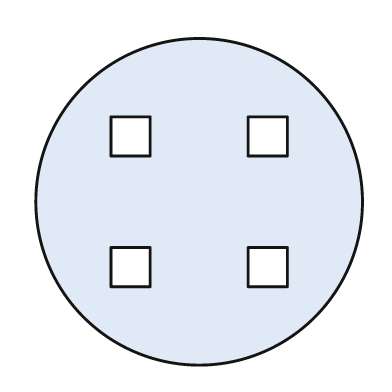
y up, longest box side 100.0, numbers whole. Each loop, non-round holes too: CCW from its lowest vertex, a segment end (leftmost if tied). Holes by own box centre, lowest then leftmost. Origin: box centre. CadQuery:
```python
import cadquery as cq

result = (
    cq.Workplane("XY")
    .moveTo(0.0, 0.0)
    .circle(50.0)
    .moveTo(-27.0, -26.0)
    .lineTo(-15.0, -26.0)
    .lineTo(-15.0, -14.0)
    .lineTo(-27.0, -14.0)
    .close()
    .moveTo(15.0, -26.0)
    .lineTo(27.0, -26.0)
    .lineTo(27.0, -14.0)
    .lineTo(15.0, -14.0)
    .close()
    .moveTo(-27.0, 14.0)
    .lineTo(-15.0, 14.0)
    .lineTo(-15.0, 26.0)
    .lineTo(-27.0, 26.0)
    .close()
    .moveTo(15.0, 14.0)
    .lineTo(27.0, 14.0)
    .lineTo(27.0, 26.0)
    .lineTo(15.0, 26.0)
    .close()
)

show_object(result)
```